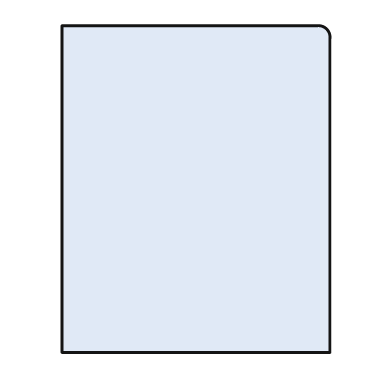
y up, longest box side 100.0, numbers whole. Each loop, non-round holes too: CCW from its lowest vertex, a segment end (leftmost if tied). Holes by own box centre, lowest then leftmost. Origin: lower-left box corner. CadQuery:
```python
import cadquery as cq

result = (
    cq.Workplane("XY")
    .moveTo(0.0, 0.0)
    .lineTo(82.0, 0.0)
    .lineTo(82.0, 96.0)
    .threePointArc((81.0, 99.0), (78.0, 100.0))
    .lineTo(0.0, 100.0)
    .close()
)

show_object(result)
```